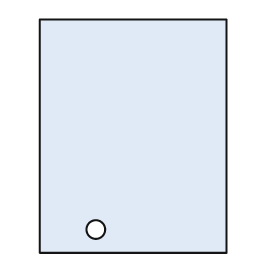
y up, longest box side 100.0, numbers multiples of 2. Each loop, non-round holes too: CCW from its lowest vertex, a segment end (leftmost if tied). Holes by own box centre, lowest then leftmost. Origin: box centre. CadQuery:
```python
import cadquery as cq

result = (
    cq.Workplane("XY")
    .moveTo(-40.0, -50.0)
    .lineTo(40.0, -50.0)
    .lineTo(40.0, 50.0)
    .lineTo(-40.0, 50.0)
    .close()
    .moveTo(-16.0, -40.0)
    .circle(4.0)
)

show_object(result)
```